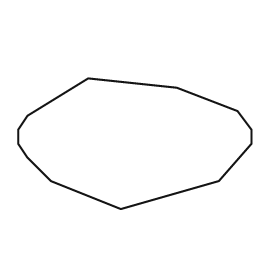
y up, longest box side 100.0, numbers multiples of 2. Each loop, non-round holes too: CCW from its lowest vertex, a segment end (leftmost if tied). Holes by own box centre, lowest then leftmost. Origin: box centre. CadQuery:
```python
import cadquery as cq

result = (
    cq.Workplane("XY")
    .moveTo(-6.0, -28.0)
    .lineTo(36.0, -16.0)
    .lineTo(50.0, 0.0)
    .lineTo(50.0, 6.0)
    .lineTo(44.0, 14.0)
    .lineTo(18.0, 24.0)
    .lineTo(-20.0, 28.0)
    .lineTo(-46.0, 12.0)
    .lineTo(-50.0, 6.0)
    .lineTo(-50.0, 0.0)
    .lineTo(-46.0, -6.0)
    .lineTo(-36.0, -16.0)
    .close()
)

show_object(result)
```